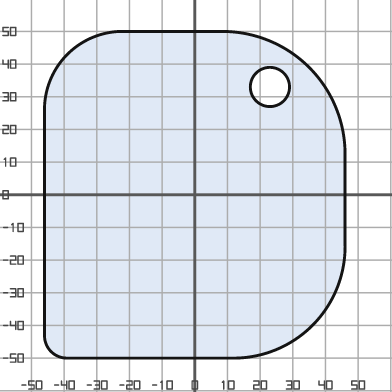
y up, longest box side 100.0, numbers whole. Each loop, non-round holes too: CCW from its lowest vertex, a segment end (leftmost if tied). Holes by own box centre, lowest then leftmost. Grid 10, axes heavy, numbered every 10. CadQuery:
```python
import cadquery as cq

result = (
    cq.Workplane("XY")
    .moveTo(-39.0, -50.0)
    .lineTo(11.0, -50.0)
    .threePointArc((36.0, -40.0), (46.0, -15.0))
    .lineTo(46.0, 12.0)
    .threePointArc((35.0, 39.0), (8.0, 50.0))
    .lineTo(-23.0, 50.0)
    .threePointArc((-39.0, 43.0), (-46.0, 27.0))
    .lineTo(-46.0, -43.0)
    .threePointArc((-44.0, -48.0), (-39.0, -50.0))
    .close()
    .moveTo(23.0, 33.0)
    .circle(6.0)
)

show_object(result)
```